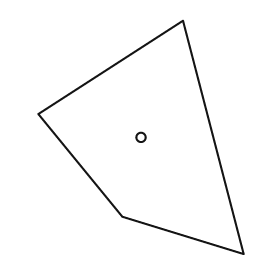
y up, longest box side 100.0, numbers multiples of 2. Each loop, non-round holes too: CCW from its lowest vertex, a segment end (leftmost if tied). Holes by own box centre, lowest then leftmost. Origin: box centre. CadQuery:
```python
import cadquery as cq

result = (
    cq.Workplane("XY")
    .moveTo(44.0, -50.0)
    .lineTo(18.0, 50.0)
    .lineTo(-44.0, 10.0)
    .lineTo(-8.0, -34.0)
    .close()
    .moveTo(0.0, 0.0)
    .circle(2.0)
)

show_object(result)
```